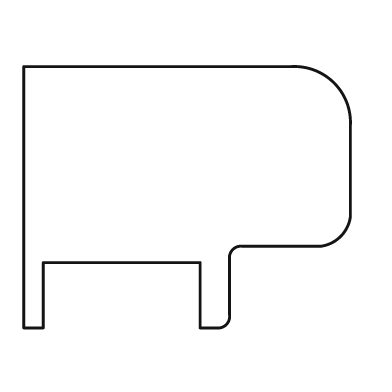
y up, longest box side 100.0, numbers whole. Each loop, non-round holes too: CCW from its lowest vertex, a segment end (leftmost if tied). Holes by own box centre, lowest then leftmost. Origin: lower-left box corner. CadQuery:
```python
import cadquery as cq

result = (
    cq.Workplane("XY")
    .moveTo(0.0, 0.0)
    .lineTo(6.0, 0.0)
    .lineTo(6.0, 20.0)
    .lineTo(54.0, 20.0)
    .lineTo(54.0, 0.0)
    .lineTo(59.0, 0.0)
    .threePointArc((62.0, 1.0), (63.0, 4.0))
    .lineTo(63.0, 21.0)
    .threePointArc((64.0, 24.0), (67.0, 25.0))
    .lineTo(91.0, 25.0)
    .threePointArc((97.0, 28.0), (100.0, 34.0))
    .lineTo(100.0, 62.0)
    .threePointArc((95.0, 75.0), (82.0, 80.0))
    .lineTo(0.0, 80.0)
    .close()
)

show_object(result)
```